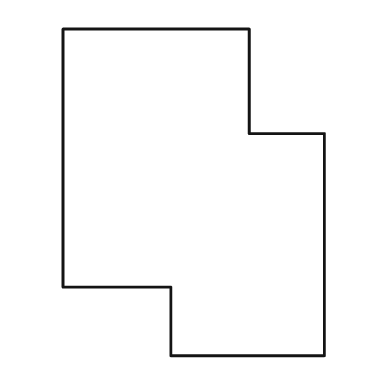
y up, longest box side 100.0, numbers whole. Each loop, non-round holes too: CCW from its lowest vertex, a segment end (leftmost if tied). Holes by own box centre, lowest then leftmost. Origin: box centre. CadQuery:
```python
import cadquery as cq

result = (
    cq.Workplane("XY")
    .moveTo(-7.0, -50.0)
    .lineTo(40.0, -50.0)
    .lineTo(40.0, 18.0)
    .lineTo(17.0, 18.0)
    .lineTo(17.0, 50.0)
    .lineTo(-40.0, 50.0)
    .lineTo(-40.0, -29.0)
    .lineTo(-7.0, -29.0)
    .close()
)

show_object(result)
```